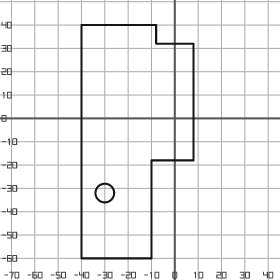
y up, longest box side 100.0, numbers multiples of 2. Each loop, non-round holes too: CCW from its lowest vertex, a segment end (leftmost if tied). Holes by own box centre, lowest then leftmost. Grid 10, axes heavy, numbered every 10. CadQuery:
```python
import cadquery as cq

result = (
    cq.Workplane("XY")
    .moveTo(-40.0, -60.0)
    .lineTo(-10.0, -60.0)
    .lineTo(-10.0, -18.0)
    .lineTo(8.0, -18.0)
    .lineTo(8.0, 32.0)
    .lineTo(-8.0, 32.0)
    .lineTo(-8.0, 40.0)
    .lineTo(-40.0, 40.0)
    .close()
    .moveTo(-30.0, -32.0)
    .circle(4.0)
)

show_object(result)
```